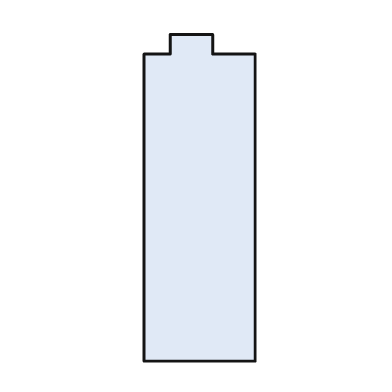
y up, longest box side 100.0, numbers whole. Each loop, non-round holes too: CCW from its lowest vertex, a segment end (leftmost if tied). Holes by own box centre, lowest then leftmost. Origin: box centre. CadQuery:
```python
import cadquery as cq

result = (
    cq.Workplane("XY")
    .moveTo(-17.0, -50.0)
    .lineTo(17.0, -50.0)
    .lineTo(17.0, 44.0)
    .lineTo(4.0, 44.0)
    .lineTo(4.0, 50.0)
    .lineTo(-9.0, 50.0)
    .lineTo(-9.0, 44.0)
    .lineTo(-17.0, 44.0)
    .close()
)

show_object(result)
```